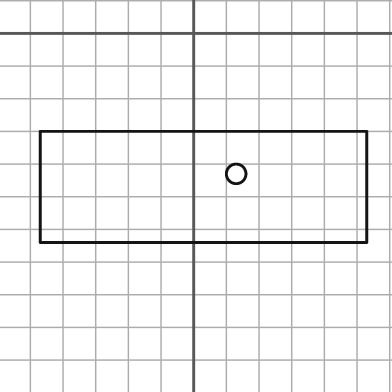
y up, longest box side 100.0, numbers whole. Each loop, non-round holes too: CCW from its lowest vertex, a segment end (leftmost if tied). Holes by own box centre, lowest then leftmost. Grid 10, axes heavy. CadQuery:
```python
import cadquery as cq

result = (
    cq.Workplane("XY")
    .moveTo(-47.0, -64.0)
    .lineTo(53.0, -64.0)
    .lineTo(53.0, -30.0)
    .lineTo(-47.0, -30.0)
    .close()
    .moveTo(13.0, -43.0)
    .circle(3.0)
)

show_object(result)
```